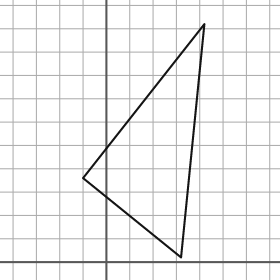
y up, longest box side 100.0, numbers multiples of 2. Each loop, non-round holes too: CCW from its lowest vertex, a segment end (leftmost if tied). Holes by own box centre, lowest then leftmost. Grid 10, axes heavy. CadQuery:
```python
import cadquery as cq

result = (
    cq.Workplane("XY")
    .moveTo(32.0, 2.0)
    .lineTo(42.0, 102.0)
    .lineTo(-10.0, 36.0)
    .close()
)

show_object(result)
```